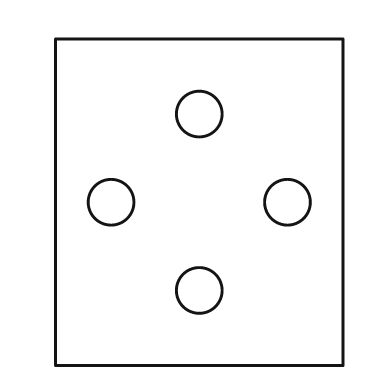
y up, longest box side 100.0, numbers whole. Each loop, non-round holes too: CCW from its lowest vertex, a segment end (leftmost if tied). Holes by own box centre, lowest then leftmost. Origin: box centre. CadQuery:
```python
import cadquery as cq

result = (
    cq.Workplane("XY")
    .moveTo(-44.0, -50.0)
    .lineTo(44.0, -50.0)
    .lineTo(44.0, 50.0)
    .lineTo(-44.0, 50.0)
    .close()
    .moveTo(0.0, -27.0)
    .circle(7.0)
    .moveTo(-27.0, 0.0)
    .circle(7.0)
    .moveTo(27.0, 0.0)
    .circle(7.0)
    .moveTo(0.0, 27.0)
    .circle(7.0)
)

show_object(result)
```